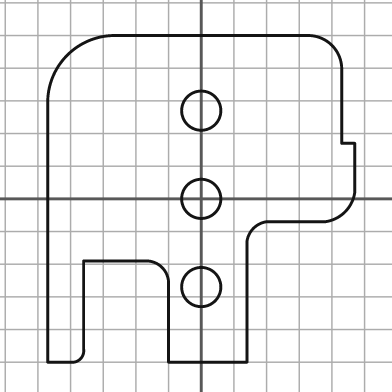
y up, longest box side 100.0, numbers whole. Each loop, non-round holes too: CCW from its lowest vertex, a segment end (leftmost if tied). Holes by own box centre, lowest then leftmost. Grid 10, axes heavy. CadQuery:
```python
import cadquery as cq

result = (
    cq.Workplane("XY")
    .moveTo(-47.0, -50.0)
    .lineTo(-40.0, -50.0)
    .threePointArc((-37.0, -49.0), (-36.0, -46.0))
    .lineTo(-36.0, -19.0)
    .lineTo(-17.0, -19.0)
    .threePointArc((-12.0, -21.0), (-10.0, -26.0))
    .lineTo(-10.0, -50.0)
    .lineTo(14.0, -50.0)
    .lineTo(14.0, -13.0)
    .threePointArc((16.0, -9.0), (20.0, -7.0))
    .lineTo(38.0, -7.0)
    .threePointArc((44.0, -4.0), (47.0, 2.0))
    .lineTo(47.0, 17.0)
    .lineTo(43.0, 17.0)
    .lineTo(43.0, 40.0)
    .threePointArc((40.0, 47.0), (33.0, 50.0))
    .lineTo(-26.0, 50.0)
    .threePointArc((-41.0, 44.0), (-47.0, 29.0))
    .close()
    .moveTo(0.0, -27.0)
    .circle(6.0)
    .moveTo(0.0, 0.0)
    .circle(6.0)
    .moveTo(0.0, 27.0)
    .circle(6.0)
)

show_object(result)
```